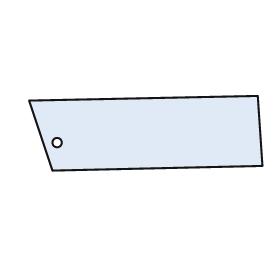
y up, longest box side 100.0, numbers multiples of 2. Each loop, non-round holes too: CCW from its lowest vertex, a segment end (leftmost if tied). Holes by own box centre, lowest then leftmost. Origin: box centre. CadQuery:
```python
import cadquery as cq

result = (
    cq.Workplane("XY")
    .moveTo(-40.0, -16.0)
    .lineTo(50.0, -14.0)
    .lineTo(48.0, 16.0)
    .lineTo(-50.0, 14.0)
    .close()
    .moveTo(-38.0, -4.0)
    .circle(2.0)
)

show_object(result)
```